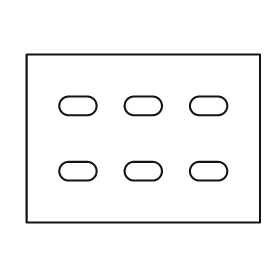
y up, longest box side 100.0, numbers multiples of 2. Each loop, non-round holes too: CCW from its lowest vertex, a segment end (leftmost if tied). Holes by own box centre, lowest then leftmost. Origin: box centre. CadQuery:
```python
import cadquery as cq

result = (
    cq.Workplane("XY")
    .moveTo(-50.0, -36.0)
    .lineTo(50.0, -36.0)
    .lineTo(50.0, 36.0)
    .lineTo(-50.0, 36.0)
    .close()
    .moveTo(-32.0, -18.0)
    .lineTo(-24.0, -18.0)
    .threePointArc((-20.0, -14.0), (-24.0, -10.0))
    .lineTo(-32.0, -10.0)
    .threePointArc((-36.0, -14.0), (-32.0, -18.0))
    .close()
    .moveTo(-4.0, -18.0)
    .lineTo(4.0, -18.0)
    .threePointArc((8.0, -14.0), (4.0, -10.0))
    .lineTo(-4.0, -10.0)
    .threePointArc((-8.0, -14.0), (-4.0, -18.0))
    .close()
    .moveTo(24.0, -18.0)
    .lineTo(32.0, -18.0)
    .threePointArc((36.0, -14.0), (32.0, -10.0))
    .lineTo(24.0, -10.0)
    .threePointArc((20.0, -14.0), (24.0, -18.0))
    .close()
    .moveTo(-32.0, 10.0)
    .lineTo(-24.0, 10.0)
    .threePointArc((-20.0, 14.0), (-24.0, 18.0))
    .lineTo(-32.0, 18.0)
    .threePointArc((-36.0, 14.0), (-32.0, 10.0))
    .close()
    .moveTo(-4.0, 10.0)
    .lineTo(4.0, 10.0)
    .threePointArc((8.0, 14.0), (4.0, 18.0))
    .lineTo(-4.0, 18.0)
    .threePointArc((-8.0, 14.0), (-4.0, 10.0))
    .close()
    .moveTo(24.0, 10.0)
    .lineTo(32.0, 10.0)
    .threePointArc((36.0, 14.0), (32.0, 18.0))
    .lineTo(24.0, 18.0)
    .threePointArc((20.0, 14.0), (24.0, 10.0))
    .close()
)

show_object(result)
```